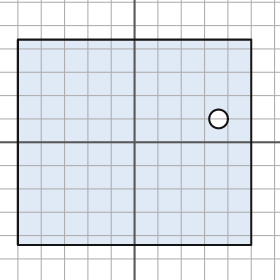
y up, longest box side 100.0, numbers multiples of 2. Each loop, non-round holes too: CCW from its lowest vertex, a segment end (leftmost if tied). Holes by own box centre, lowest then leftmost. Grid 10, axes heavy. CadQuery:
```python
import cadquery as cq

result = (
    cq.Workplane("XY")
    .moveTo(-50.0, -44.0)
    .lineTo(50.0, -44.0)
    .lineTo(50.0, 44.0)
    .lineTo(-50.0, 44.0)
    .close()
    .moveTo(36.0, 10.0)
    .circle(4.0)
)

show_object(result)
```